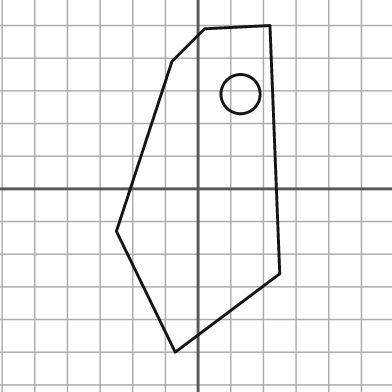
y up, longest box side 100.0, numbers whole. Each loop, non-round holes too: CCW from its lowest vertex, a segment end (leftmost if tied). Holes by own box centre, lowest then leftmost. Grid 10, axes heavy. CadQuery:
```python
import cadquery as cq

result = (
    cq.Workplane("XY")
    .moveTo(-7.0, -50.0)
    .lineTo(25.0, -26.0)
    .lineTo(22.0, 50.0)
    .lineTo(2.0, 49.0)
    .lineTo(-8.0, 39.0)
    .lineTo(-25.0, -13.0)
    .close()
    .moveTo(13.0, 29.0)
    .circle(6.0)
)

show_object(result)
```